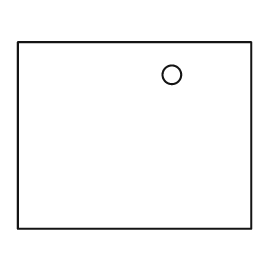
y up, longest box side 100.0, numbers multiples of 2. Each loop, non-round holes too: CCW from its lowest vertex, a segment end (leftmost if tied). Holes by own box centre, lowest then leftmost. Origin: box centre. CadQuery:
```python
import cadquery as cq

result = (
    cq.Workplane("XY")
    .moveTo(-50.0, -40.0)
    .lineTo(50.0, -40.0)
    .lineTo(50.0, 40.0)
    .lineTo(-50.0, 40.0)
    .close()
    .moveTo(16.0, 26.0)
    .circle(4.0)
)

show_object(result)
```